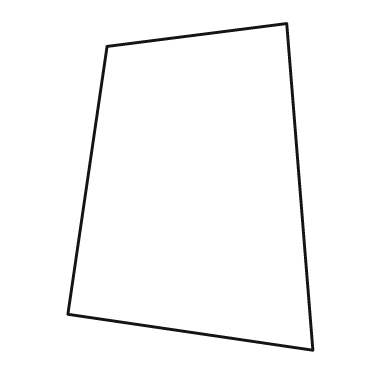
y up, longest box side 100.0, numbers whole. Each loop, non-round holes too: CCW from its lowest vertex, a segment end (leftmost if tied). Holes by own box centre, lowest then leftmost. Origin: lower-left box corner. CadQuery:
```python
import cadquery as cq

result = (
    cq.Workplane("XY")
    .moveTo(75.0, 0.0)
    .lineTo(67.0, 100.0)
    .lineTo(12.0, 93.0)
    .lineTo(0.0, 11.0)
    .close()
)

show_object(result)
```